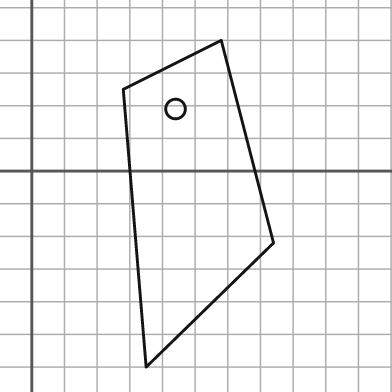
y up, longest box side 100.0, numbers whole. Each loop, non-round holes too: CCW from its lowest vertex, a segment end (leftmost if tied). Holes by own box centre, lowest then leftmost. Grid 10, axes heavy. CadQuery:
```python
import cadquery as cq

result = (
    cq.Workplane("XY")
    .moveTo(35.0, -60.0)
    .lineTo(74.0, -22.0)
    .lineTo(58.0, 40.0)
    .lineTo(28.0, 25.0)
    .close()
    .moveTo(44.0, 19.0)
    .circle(3.0)
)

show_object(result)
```